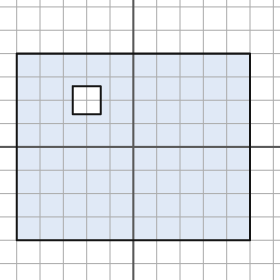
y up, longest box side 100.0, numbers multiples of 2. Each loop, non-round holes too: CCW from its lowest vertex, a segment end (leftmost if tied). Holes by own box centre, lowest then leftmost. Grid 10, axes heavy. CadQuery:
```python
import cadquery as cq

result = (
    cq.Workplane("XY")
    .moveTo(-50.0, -40.0)
    .lineTo(50.0, -40.0)
    .lineTo(50.0, 40.0)
    .lineTo(-50.0, 40.0)
    .close()
    .moveTo(-26.0, 14.0)
    .lineTo(-14.0, 14.0)
    .lineTo(-14.0, 26.0)
    .lineTo(-26.0, 26.0)
    .close()
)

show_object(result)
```